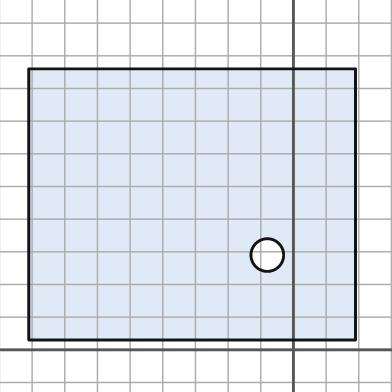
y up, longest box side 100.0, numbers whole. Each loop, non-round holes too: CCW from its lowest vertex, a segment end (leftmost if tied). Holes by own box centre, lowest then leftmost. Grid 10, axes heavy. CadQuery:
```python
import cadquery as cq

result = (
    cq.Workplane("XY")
    .moveTo(-81.0, 3.0)
    .lineTo(19.0, 3.0)
    .lineTo(19.0, 86.0)
    .lineTo(-81.0, 86.0)
    .close()
    .moveTo(-8.0, 29.0)
    .circle(5.0)
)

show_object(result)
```